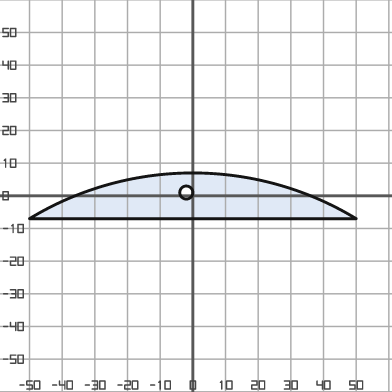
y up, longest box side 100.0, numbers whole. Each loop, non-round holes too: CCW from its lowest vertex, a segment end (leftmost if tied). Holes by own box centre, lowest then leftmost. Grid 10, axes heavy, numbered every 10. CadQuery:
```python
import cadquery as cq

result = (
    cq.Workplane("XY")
    .moveTo(-50.0, -7.0)
    .lineTo(50.0, -7.0)
    .threePointArc((0.0, 7.0), (-50.0, -7.0))
    .close()
    .moveTo(-2.0, 1.0)
    .circle(2.0)
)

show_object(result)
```